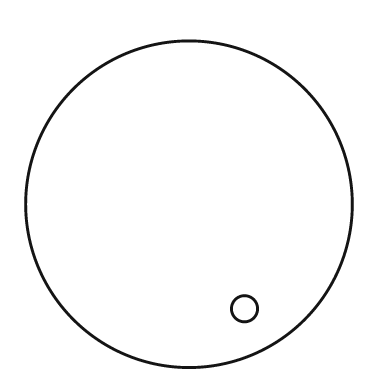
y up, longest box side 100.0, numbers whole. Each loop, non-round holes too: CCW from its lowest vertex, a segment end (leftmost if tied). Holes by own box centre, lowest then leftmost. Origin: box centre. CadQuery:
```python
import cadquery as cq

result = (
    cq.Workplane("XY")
    .moveTo(0.0, 0.0)
    .circle(50.0)
    .moveTo(17.0, -32.0)
    .circle(4.0)
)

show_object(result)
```